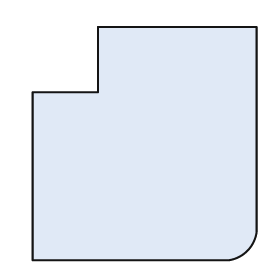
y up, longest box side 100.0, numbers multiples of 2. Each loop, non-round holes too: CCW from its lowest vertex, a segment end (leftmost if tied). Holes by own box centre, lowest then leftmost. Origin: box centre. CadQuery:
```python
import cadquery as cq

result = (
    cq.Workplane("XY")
    .moveTo(-48.0, -50.0)
    .lineTo(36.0, -50.0)
    .threePointArc((44.0, -46.0), (48.0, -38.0))
    .lineTo(48.0, 50.0)
    .lineTo(-20.0, 50.0)
    .lineTo(-20.0, 22.0)
    .lineTo(-48.0, 22.0)
    .close()
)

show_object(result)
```